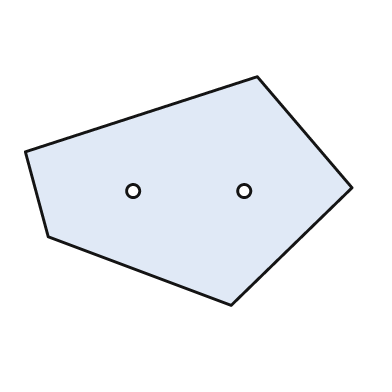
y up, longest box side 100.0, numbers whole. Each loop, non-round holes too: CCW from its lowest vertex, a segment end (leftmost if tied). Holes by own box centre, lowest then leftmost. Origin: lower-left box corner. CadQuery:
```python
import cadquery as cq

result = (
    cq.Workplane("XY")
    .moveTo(63.0, 0.0)
    .lineTo(100.0, 36.0)
    .lineTo(71.0, 70.0)
    .lineTo(0.0, 47.0)
    .lineTo(7.0, 21.0)
    .close()
    .moveTo(33.0, 35.0)
    .circle(2.0)
    .moveTo(67.0, 35.0)
    .circle(2.0)
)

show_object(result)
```